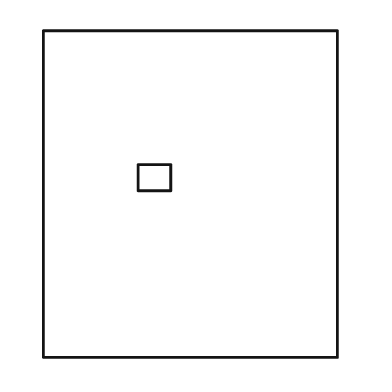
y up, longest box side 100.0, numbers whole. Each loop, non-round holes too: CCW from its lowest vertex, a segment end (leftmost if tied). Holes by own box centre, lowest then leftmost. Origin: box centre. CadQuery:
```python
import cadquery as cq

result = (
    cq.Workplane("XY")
    .moveTo(-45.0, -50.0)
    .lineTo(45.0, -50.0)
    .lineTo(45.0, 50.0)
    .lineTo(-45.0, 50.0)
    .close()
    .moveTo(-16.0, 1.0)
    .lineTo(-6.0, 1.0)
    .lineTo(-6.0, 9.0)
    .lineTo(-16.0, 9.0)
    .close()
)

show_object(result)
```